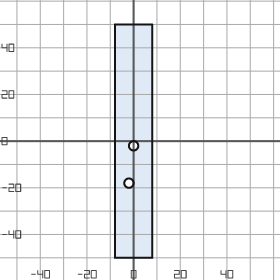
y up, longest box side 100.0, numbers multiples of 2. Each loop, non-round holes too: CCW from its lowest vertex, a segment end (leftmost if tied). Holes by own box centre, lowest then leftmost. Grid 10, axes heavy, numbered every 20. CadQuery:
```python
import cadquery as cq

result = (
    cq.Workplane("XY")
    .moveTo(-8.0, -50.0)
    .lineTo(8.0, -50.0)
    .lineTo(8.0, 50.0)
    .lineTo(-8.0, 50.0)
    .close()
    .moveTo(-2.0, -18.0)
    .circle(2.0)
    .moveTo(0.0, -2.0)
    .circle(2.0)
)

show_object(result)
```